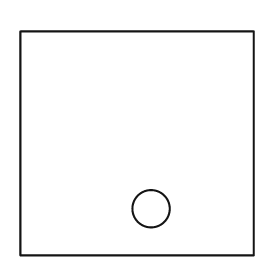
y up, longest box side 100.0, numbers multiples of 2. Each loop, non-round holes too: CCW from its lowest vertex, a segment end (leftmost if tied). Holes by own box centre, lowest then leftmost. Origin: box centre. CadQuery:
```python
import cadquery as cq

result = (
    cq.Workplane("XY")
    .moveTo(-50.0, -48.0)
    .lineTo(50.0, -48.0)
    .lineTo(50.0, 48.0)
    .lineTo(-50.0, 48.0)
    .close()
    .moveTo(6.0, -28.0)
    .circle(8.0)
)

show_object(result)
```